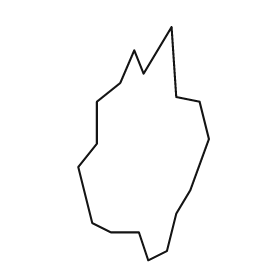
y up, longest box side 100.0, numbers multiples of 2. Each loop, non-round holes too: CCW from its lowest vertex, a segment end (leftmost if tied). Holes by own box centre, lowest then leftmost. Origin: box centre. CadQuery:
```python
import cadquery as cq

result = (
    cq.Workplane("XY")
    .moveTo(2.0, -50.0)
    .lineTo(10.0, -46.0)
    .lineTo(14.0, -30.0)
    .lineTo(20.0, -20.0)
    .lineTo(28.0, 2.0)
    .lineTo(24.0, 18.0)
    .lineTo(14.0, 20.0)
    .lineTo(12.0, 50.0)
    .lineTo(0.0, 30.0)
    .lineTo(-4.0, 40.0)
    .lineTo(-10.0, 26.0)
    .lineTo(-20.0, 18.0)
    .lineTo(-20.0, 0.0)
    .lineTo(-28.0, -10.0)
    .lineTo(-22.0, -34.0)
    .lineTo(-14.0, -38.0)
    .lineTo(-2.0, -38.0)
    .close()
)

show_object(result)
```